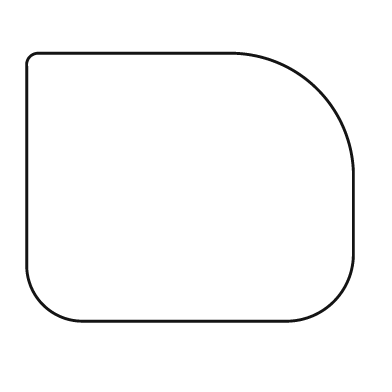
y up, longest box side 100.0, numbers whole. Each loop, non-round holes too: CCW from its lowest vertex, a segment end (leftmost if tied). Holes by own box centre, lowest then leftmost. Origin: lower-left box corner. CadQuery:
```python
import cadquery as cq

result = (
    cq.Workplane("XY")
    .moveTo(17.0, 0.0)
    .lineTo(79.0, 0.0)
    .threePointArc((94.0, 6.0), (100.0, 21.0))
    .lineTo(100.0, 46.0)
    .threePointArc((89.0, 71.0), (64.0, 82.0))
    .lineTo(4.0, 82.0)
    .threePointArc((1.0, 81.0), (0.0, 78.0))
    .lineTo(0.0, 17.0)
    .threePointArc((5.0, 5.0), (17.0, 0.0))
    .close()
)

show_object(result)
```